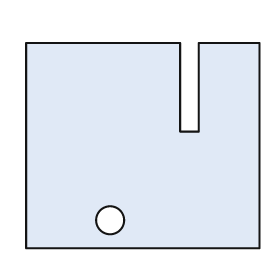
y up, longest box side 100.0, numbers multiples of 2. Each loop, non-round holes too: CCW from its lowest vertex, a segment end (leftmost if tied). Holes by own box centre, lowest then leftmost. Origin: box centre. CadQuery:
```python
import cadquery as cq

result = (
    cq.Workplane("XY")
    .moveTo(-50.0, -44.0)
    .lineTo(50.0, -44.0)
    .lineTo(50.0, 44.0)
    .lineTo(24.0, 44.0)
    .lineTo(24.0, 6.0)
    .lineTo(16.0, 6.0)
    .lineTo(16.0, 44.0)
    .lineTo(-50.0, 44.0)
    .close()
    .moveTo(-14.0, -32.0)
    .circle(6.0)
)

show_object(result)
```